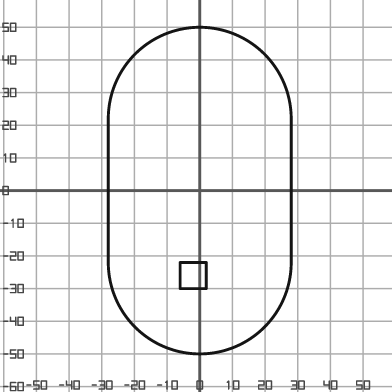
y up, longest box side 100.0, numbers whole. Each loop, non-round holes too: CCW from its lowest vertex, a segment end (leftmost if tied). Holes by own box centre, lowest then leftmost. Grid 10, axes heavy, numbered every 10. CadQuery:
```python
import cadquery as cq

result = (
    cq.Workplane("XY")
    .moveTo(-28.0, -22.0)
    .threePointArc((0.0, -50.0), (28.0, -22.0))
    .lineTo(28.0, 22.0)
    .threePointArc((0.0, 50.0), (-28.0, 22.0))
    .close()
    .moveTo(-6.0, -30.0)
    .lineTo(2.0, -30.0)
    .lineTo(2.0, -22.0)
    .lineTo(-6.0, -22.0)
    .close()
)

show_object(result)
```